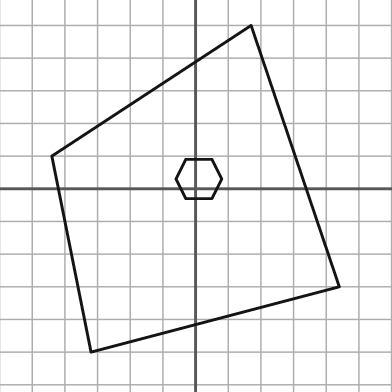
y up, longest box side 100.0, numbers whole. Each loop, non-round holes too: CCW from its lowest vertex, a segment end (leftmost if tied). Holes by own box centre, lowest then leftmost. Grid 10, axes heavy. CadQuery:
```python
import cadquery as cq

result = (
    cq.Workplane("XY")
    .moveTo(-32.0, -50.0)
    .lineTo(44.0, -30.0)
    .lineTo(17.0, 50.0)
    .lineTo(-44.0, 10.0)
    .close()
    .moveTo(-3.0, -3.0)
    .lineTo(5.0, -3.0)
    .lineTo(8.0, 3.0)
    .lineTo(5.0, 9.0)
    .lineTo(-3.0, 9.0)
    .lineTo(-6.0, 3.0)
    .close()
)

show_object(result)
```